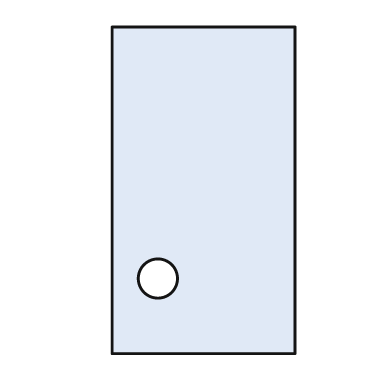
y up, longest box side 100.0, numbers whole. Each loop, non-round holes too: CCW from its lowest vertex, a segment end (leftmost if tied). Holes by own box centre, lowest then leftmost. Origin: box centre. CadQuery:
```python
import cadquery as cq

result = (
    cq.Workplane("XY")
    .moveTo(-28.0, -50.0)
    .lineTo(28.0, -50.0)
    .lineTo(28.0, 50.0)
    .lineTo(-28.0, 50.0)
    .close()
    .moveTo(-14.0, -27.0)
    .circle(6.0)
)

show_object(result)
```